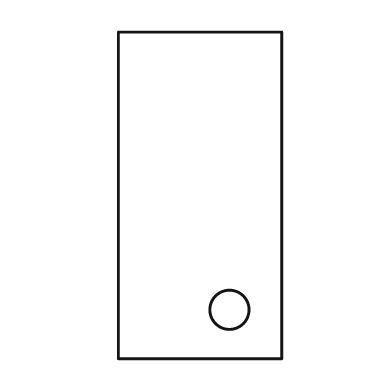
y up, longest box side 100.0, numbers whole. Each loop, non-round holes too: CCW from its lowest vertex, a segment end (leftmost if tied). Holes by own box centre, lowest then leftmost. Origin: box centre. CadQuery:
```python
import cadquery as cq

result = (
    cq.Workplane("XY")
    .moveTo(-25.0, -50.0)
    .lineTo(25.0, -50.0)
    .lineTo(25.0, 50.0)
    .lineTo(-25.0, 50.0)
    .close()
    .moveTo(9.0, -35.0)
    .circle(6.0)
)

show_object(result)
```